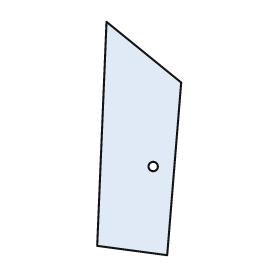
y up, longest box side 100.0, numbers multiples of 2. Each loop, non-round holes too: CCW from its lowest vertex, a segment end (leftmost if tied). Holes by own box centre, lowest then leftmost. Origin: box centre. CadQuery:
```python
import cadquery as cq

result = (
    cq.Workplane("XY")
    .moveTo(12.0, -50.0)
    .lineTo(18.0, 24.0)
    .lineTo(-14.0, 50.0)
    .lineTo(-18.0, -46.0)
    .close()
    .moveTo(6.0, -12.0)
    .circle(2.0)
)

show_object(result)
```